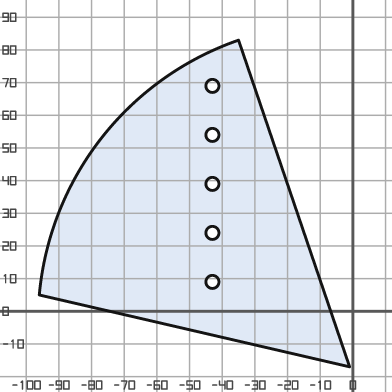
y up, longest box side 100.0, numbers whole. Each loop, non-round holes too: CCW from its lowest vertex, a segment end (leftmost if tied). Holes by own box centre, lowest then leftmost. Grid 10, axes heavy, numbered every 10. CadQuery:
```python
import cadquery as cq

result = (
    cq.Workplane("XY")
    .moveTo(-1.0, -17.0)
    .lineTo(-35.0, 83.0)
    .threePointArc((-77.0, 53.0), (-96.0, 5.0))
    .close()
    .moveTo(-43.0, 9.0)
    .circle(2.0)
    .moveTo(-43.0, 24.0)
    .circle(2.0)
    .moveTo(-43.0, 39.0)
    .circle(2.0)
    .moveTo(-43.0, 54.0)
    .circle(2.0)
    .moveTo(-43.0, 69.0)
    .circle(2.0)
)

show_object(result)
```